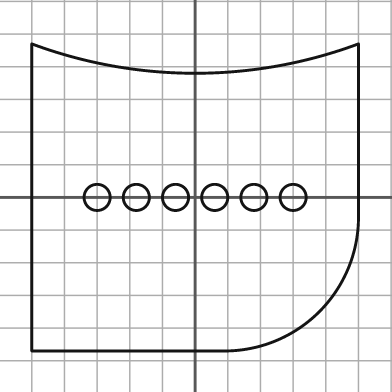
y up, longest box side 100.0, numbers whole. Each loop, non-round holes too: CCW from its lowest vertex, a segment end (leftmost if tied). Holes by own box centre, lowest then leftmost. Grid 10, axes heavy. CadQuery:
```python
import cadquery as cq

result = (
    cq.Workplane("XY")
    .moveTo(-50.0, -47.0)
    .lineTo(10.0, -47.0)
    .threePointArc((38.0, -35.0), (50.0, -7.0))
    .lineTo(50.0, 47.0)
    .threePointArc((0.0, 38.0), (-50.0, 47.0))
    .close()
    .moveTo(-30.0, 0.0)
    .circle(4.0)
    .moveTo(-18.0, 0.0)
    .circle(4.0)
    .moveTo(-6.0, 0.0)
    .circle(4.0)
    .moveTo(6.0, 0.0)
    .circle(4.0)
    .moveTo(18.0, 0.0)
    .circle(4.0)
    .moveTo(30.0, 0.0)
    .circle(4.0)
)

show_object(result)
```